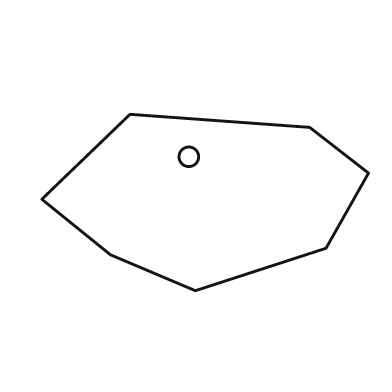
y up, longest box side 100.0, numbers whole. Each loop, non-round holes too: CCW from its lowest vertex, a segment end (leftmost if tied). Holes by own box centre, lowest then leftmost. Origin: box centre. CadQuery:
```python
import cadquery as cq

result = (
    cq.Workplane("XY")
    .moveTo(-3.0, -27.0)
    .lineTo(37.0, -14.0)
    .lineTo(50.0, 9.0)
    .lineTo(32.0, 23.0)
    .lineTo(-23.0, 27.0)
    .lineTo(-50.0, 1.0)
    .lineTo(-29.0, -16.0)
    .close()
    .moveTo(-5.0, 14.0)
    .circle(3.0)
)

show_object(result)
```